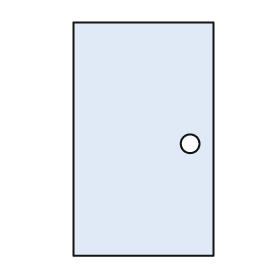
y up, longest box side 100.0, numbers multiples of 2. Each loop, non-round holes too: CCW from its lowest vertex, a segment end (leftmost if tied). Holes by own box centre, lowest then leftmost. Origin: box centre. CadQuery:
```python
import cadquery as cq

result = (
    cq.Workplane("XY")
    .moveTo(-30.0, -50.0)
    .lineTo(30.0, -50.0)
    .lineTo(30.0, 50.0)
    .lineTo(-30.0, 50.0)
    .close()
    .moveTo(20.0, -2.0)
    .circle(4.0)
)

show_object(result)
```